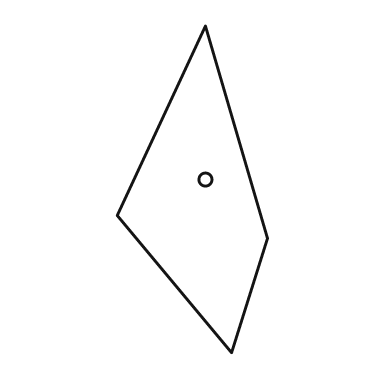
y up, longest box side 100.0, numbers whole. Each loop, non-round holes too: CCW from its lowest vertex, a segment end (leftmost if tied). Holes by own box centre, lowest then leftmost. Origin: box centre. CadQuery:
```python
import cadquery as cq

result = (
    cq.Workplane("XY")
    .moveTo(12.0, -50.0)
    .lineTo(23.0, -15.0)
    .lineTo(4.0, 50.0)
    .lineTo(-23.0, -8.0)
    .close()
    .moveTo(4.0, 3.0)
    .circle(2.0)
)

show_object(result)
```